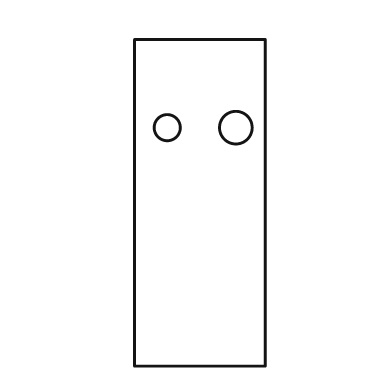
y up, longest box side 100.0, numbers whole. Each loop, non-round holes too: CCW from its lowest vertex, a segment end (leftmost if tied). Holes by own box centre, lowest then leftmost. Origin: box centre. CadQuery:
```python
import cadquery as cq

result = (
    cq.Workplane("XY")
    .moveTo(-20.0, -50.0)
    .lineTo(20.0, -50.0)
    .lineTo(20.0, 50.0)
    .lineTo(-20.0, 50.0)
    .close()
    .moveTo(-10.0, 23.0)
    .circle(4.0)
    .moveTo(11.0, 23.0)
    .circle(5.0)
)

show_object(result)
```